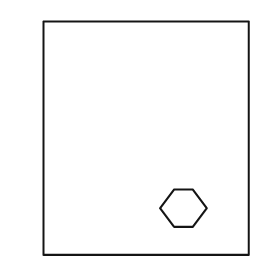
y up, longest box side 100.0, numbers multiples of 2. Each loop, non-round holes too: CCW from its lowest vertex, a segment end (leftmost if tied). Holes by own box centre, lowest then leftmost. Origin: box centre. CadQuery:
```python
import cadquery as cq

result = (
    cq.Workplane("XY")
    .moveTo(-44.0, -50.0)
    .lineTo(44.0, -50.0)
    .lineTo(44.0, 50.0)
    .lineTo(-44.0, 50.0)
    .close()
    .moveTo(12.0, -38.0)
    .lineTo(20.0, -38.0)
    .lineTo(26.0, -30.0)
    .lineTo(20.0, -22.0)
    .lineTo(12.0, -22.0)
    .lineTo(6.0, -30.0)
    .close()
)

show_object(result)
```